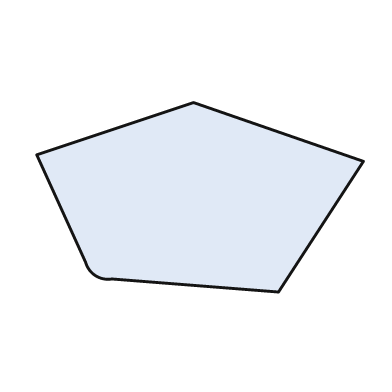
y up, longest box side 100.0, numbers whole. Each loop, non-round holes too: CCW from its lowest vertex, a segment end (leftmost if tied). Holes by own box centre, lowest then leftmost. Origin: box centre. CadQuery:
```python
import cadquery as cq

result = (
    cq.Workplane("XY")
    .moveTo(24.0, -29.0)
    .lineTo(50.0, 11.0)
    .lineTo(-2.0, 29.0)
    .lineTo(-50.0, 13.0)
    .lineTo(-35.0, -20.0)
    .threePointArc((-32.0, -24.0), (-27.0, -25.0))
    .close()
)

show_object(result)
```